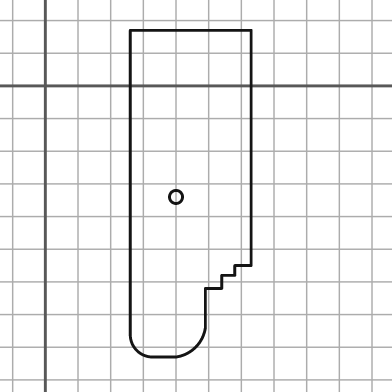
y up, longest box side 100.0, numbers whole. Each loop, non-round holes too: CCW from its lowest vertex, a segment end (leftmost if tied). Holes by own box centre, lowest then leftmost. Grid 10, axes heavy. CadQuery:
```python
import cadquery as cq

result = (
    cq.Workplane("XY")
    .moveTo(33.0, -83.0)
    .lineTo(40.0, -83.0)
    .threePointArc((46.0, -80.0), (49.0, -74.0))
    .lineTo(49.0, -62.0)
    .lineTo(54.0, -62.0)
    .lineTo(54.0, -58.0)
    .lineTo(58.0, -58.0)
    .lineTo(58.0, -55.0)
    .lineTo(63.0, -55.0)
    .lineTo(63.0, 17.0)
    .lineTo(26.0, 17.0)
    .lineTo(26.0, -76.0)
    .threePointArc((28.0, -81.0), (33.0, -83.0))
    .close()
    .moveTo(40.0, -34.0)
    .circle(2.0)
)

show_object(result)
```